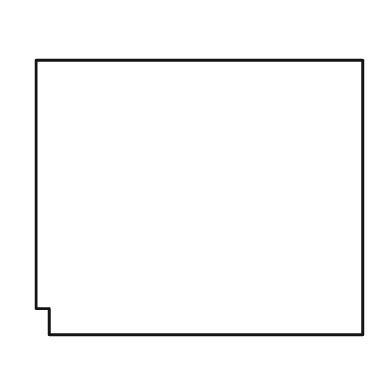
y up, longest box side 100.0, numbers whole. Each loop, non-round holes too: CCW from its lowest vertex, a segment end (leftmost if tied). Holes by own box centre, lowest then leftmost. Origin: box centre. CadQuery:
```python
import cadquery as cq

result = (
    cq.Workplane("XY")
    .moveTo(-46.0, -42.0)
    .lineTo(50.0, -42.0)
    .lineTo(50.0, 42.0)
    .lineTo(-50.0, 42.0)
    .lineTo(-50.0, -34.0)
    .lineTo(-46.0, -34.0)
    .close()
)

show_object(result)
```